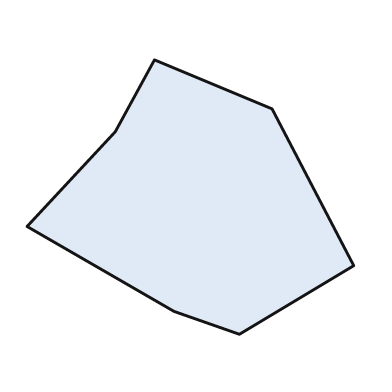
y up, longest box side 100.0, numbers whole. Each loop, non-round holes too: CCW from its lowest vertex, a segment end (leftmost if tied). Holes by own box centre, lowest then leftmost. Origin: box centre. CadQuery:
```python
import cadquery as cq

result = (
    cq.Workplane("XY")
    .moveTo(15.0, -42.0)
    .lineTo(50.0, -21.0)
    .lineTo(25.0, 27.0)
    .lineTo(-11.0, 42.0)
    .lineTo(-23.0, 20.0)
    .lineTo(-50.0, -9.0)
    .lineTo(-5.0, -35.0)
    .close()
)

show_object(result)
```